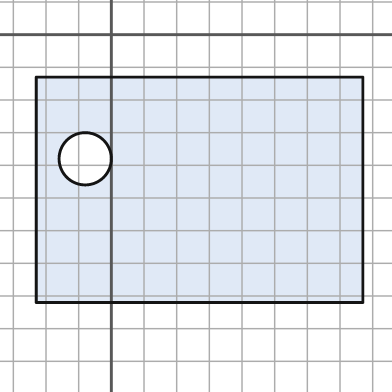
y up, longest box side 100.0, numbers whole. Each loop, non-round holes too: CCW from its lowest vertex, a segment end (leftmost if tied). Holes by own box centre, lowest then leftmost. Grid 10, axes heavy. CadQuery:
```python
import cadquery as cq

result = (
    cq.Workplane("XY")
    .moveTo(-23.0, -82.0)
    .lineTo(77.0, -82.0)
    .lineTo(77.0, -13.0)
    .lineTo(-23.0, -13.0)
    .close()
    .moveTo(-8.0, -38.0)
    .circle(8.0)
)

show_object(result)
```